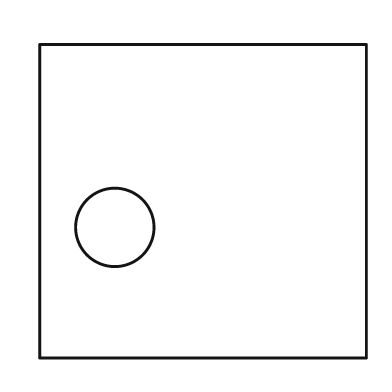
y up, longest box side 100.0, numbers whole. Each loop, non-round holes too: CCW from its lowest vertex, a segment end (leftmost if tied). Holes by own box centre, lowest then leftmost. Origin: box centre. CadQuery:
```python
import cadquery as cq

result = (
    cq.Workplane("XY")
    .moveTo(-50.0, -48.0)
    .lineTo(50.0, -48.0)
    .lineTo(50.0, 48.0)
    .lineTo(-50.0, 48.0)
    .close()
    .moveTo(-27.0, -8.0)
    .circle(12.0)
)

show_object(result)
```